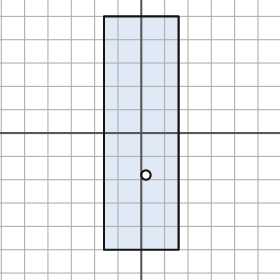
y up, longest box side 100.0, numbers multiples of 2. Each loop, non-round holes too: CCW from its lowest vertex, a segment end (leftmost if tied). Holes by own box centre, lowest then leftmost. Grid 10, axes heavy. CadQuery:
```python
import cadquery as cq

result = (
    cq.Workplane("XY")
    .moveTo(-16.0, -50.0)
    .lineTo(16.0, -50.0)
    .lineTo(16.0, 50.0)
    .lineTo(-16.0, 50.0)
    .close()
    .moveTo(2.0, -18.0)
    .circle(2.0)
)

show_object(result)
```